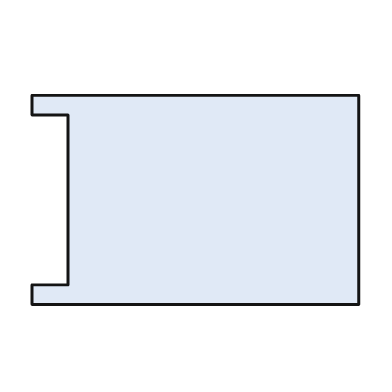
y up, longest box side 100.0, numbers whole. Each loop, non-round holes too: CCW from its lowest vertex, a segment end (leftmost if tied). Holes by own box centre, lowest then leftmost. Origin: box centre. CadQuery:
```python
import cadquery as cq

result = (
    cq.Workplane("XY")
    .moveTo(-50.0, -32.0)
    .lineTo(50.0, -32.0)
    .lineTo(50.0, 32.0)
    .lineTo(-50.0, 32.0)
    .lineTo(-50.0, 26.0)
    .lineTo(-39.0, 26.0)
    .lineTo(-39.0, -26.0)
    .lineTo(-50.0, -26.0)
    .close()
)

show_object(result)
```